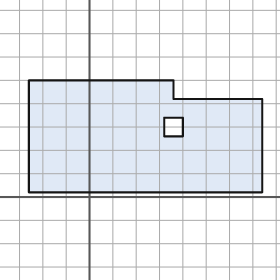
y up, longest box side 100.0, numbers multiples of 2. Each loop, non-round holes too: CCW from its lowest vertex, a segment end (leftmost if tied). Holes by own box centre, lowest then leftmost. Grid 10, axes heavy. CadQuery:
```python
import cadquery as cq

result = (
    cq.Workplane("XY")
    .moveTo(-26.0, 2.0)
    .lineTo(74.0, 2.0)
    .lineTo(74.0, 42.0)
    .lineTo(36.0, 42.0)
    .lineTo(36.0, 50.0)
    .lineTo(-26.0, 50.0)
    .close()
    .moveTo(32.0, 26.0)
    .lineTo(40.0, 26.0)
    .lineTo(40.0, 34.0)
    .lineTo(32.0, 34.0)
    .close()
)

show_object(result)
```